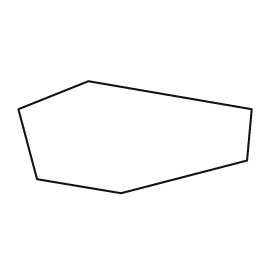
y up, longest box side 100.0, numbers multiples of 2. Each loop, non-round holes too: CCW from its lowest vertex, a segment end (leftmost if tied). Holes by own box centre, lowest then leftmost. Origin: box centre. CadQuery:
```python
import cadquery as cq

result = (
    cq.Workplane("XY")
    .moveTo(-6.0, -24.0)
    .lineTo(48.0, -10.0)
    .lineTo(50.0, 12.0)
    .lineTo(-20.0, 24.0)
    .lineTo(-50.0, 12.0)
    .lineTo(-42.0, -18.0)
    .close()
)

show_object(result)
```